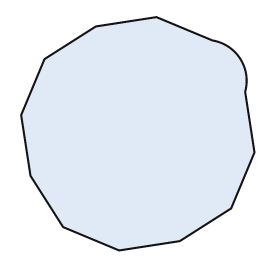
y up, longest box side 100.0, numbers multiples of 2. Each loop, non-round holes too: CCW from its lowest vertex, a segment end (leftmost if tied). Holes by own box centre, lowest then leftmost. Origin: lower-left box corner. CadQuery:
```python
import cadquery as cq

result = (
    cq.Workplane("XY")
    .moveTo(42.0, 0.0)
    .lineTo(68.0, 4.0)
    .lineTo(90.0, 18.0)
    .lineTo(100.0, 42.0)
    .lineTo(96.0, 68.0)
    .threePointArc((94.0, 82.0), (82.0, 90.0))
    .lineTo(58.0, 100.0)
    .lineTo(32.0, 96.0)
    .lineTo(10.0, 82.0)
    .lineTo(0.0, 58.0)
    .lineTo(4.0, 32.0)
    .lineTo(18.0, 10.0)
    .close()
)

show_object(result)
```